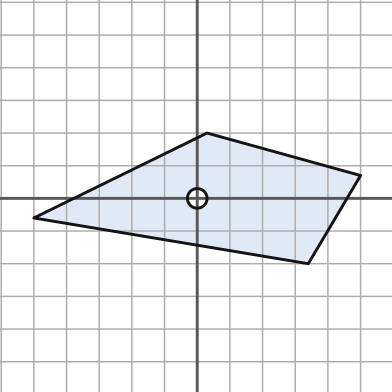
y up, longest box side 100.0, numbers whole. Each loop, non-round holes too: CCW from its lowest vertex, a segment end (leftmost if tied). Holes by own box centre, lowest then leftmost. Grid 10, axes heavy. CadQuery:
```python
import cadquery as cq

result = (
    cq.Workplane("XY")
    .moveTo(34.0, -20.0)
    .lineTo(50.0, 7.0)
    .lineTo(3.0, 20.0)
    .lineTo(-50.0, -6.0)
    .close()
    .moveTo(0.0, 0.0)
    .circle(3.0)
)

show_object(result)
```